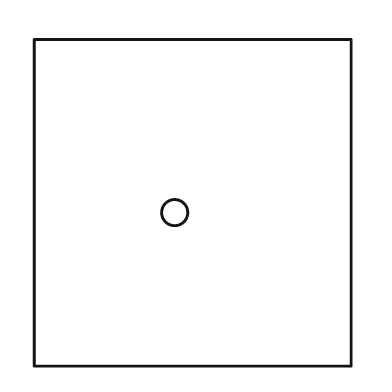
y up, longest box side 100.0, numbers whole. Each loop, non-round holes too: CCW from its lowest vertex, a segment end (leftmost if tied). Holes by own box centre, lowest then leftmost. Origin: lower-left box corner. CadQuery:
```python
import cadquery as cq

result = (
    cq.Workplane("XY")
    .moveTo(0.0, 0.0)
    .lineTo(97.0, 0.0)
    .lineTo(97.0, 100.0)
    .lineTo(0.0, 100.0)
    .close()
    .moveTo(43.0, 47.0)
    .circle(4.0)
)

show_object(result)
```